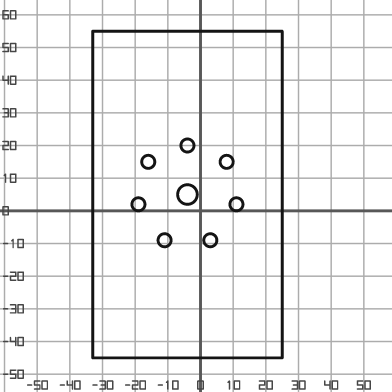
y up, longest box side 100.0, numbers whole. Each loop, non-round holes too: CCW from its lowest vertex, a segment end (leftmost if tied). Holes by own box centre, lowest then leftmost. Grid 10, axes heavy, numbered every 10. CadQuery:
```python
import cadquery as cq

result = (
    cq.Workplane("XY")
    .moveTo(-33.0, -45.0)
    .lineTo(25.0, -45.0)
    .lineTo(25.0, 55.0)
    .lineTo(-33.0, 55.0)
    .close()
    .moveTo(-11.0, -9.0)
    .circle(2.0)
    .moveTo(3.0, -9.0)
    .circle(2.0)
    .moveTo(-19.0, 2.0)
    .circle(2.0)
    .moveTo(11.0, 2.0)
    .circle(2.0)
    .moveTo(-4.0, 5.0)
    .circle(3.0)
    .moveTo(-16.0, 15.0)
    .circle(2.0)
    .moveTo(8.0, 15.0)
    .circle(2.0)
    .moveTo(-4.0, 20.0)
    .circle(2.0)
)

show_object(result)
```